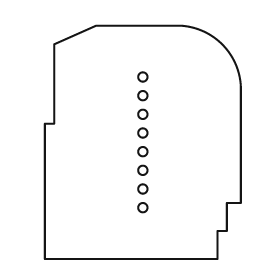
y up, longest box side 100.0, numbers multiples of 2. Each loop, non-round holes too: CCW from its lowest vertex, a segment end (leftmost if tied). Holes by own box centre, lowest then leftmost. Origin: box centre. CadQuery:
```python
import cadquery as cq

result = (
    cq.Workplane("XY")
    .moveTo(-42.0, -50.0)
    .lineTo(32.0, -50.0)
    .lineTo(32.0, -38.0)
    .lineTo(36.0, -38.0)
    .lineTo(36.0, -26.0)
    .lineTo(42.0, -26.0)
    .lineTo(42.0, 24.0)
    .threePointArc((34.0, 42.0), (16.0, 50.0))
    .lineTo(-20.0, 50.0)
    .lineTo(-38.0, 42.0)
    .lineTo(-38.0, 8.0)
    .lineTo(-42.0, 8.0)
    .close()
    .moveTo(0.0, -28.0)
    .circle(2.0)
    .moveTo(0.0, -20.0)
    .circle(2.0)
    .moveTo(0.0, -12.0)
    .circle(2.0)
    .moveTo(0.0, -4.0)
    .circle(2.0)
    .moveTo(0.0, 4.0)
    .circle(2.0)
    .moveTo(0.0, 12.0)
    .circle(2.0)
    .moveTo(0.0, 20.0)
    .circle(2.0)
    .moveTo(0.0, 28.0)
    .circle(2.0)
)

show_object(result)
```